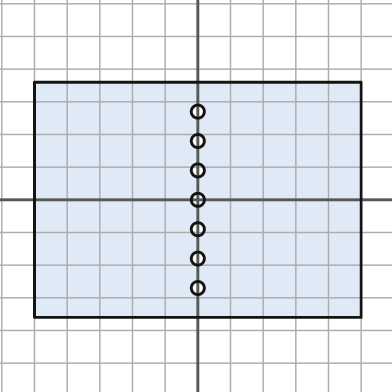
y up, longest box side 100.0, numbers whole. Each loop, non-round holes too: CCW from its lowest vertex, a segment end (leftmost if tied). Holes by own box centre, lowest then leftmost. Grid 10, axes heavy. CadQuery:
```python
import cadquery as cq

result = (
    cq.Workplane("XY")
    .moveTo(-50.0, -36.0)
    .lineTo(50.0, -36.0)
    .lineTo(50.0, 36.0)
    .lineTo(-50.0, 36.0)
    .close()
    .moveTo(0.0, -27.0)
    .circle(2.0)
    .moveTo(0.0, -18.0)
    .circle(2.0)
    .moveTo(0.0, -9.0)
    .circle(2.0)
    .moveTo(0.0, 0.0)
    .circle(2.0)
    .moveTo(0.0, 9.0)
    .circle(2.0)
    .moveTo(0.0, 18.0)
    .circle(2.0)
    .moveTo(0.0, 27.0)
    .circle(2.0)
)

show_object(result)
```